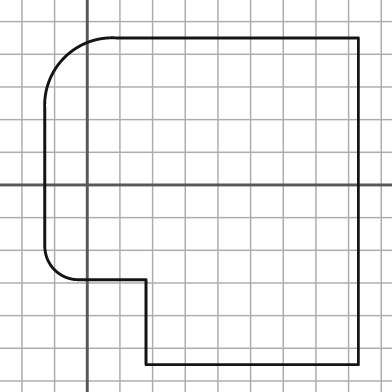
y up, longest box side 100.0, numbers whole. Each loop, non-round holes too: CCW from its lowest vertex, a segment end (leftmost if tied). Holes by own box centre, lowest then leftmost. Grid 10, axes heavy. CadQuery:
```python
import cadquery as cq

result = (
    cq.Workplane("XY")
    .moveTo(18.0, -55.0)
    .lineTo(83.0, -55.0)
    .lineTo(83.0, 45.0)
    .lineTo(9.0, 45.0)
    .threePointArc((-7.0, 39.0), (-13.0, 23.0))
    .lineTo(-13.0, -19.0)
    .threePointArc((-10.0, -26.0), (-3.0, -29.0))
    .lineTo(18.0, -29.0)
    .close()
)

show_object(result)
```